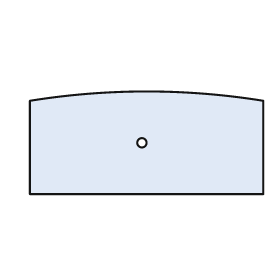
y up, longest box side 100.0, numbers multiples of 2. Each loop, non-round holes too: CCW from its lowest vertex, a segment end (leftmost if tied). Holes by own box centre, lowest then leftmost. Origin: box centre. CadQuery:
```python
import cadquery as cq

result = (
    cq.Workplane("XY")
    .moveTo(-50.0, -22.0)
    .lineTo(50.0, -22.0)
    .lineTo(50.0, 18.0)
    .threePointArc((0.0, 22.0), (-50.0, 18.0))
    .close()
    .moveTo(-2.0, 0.0)
    .circle(2.0)
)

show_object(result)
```